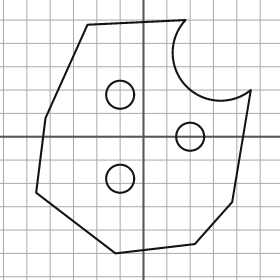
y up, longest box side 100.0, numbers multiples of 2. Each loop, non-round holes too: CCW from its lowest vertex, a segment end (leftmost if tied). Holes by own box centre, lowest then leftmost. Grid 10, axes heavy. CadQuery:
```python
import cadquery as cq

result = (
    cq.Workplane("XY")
    .moveTo(-12.0, -50.0)
    .lineTo(22.0, -46.0)
    .lineTo(38.0, -28.0)
    .lineTo(46.0, 20.0)
    .threePointArc((18.0, 22.0), (18.0, 50.0))
    .lineTo(-24.0, 48.0)
    .lineTo(-42.0, 8.0)
    .lineTo(-46.0, -24.0)
    .close()
    .moveTo(-10.0, -18.0)
    .circle(6.0)
    .moveTo(20.0, 0.0)
    .circle(6.0)
    .moveTo(-10.0, 18.0)
    .circle(6.0)
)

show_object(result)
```